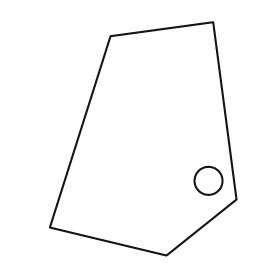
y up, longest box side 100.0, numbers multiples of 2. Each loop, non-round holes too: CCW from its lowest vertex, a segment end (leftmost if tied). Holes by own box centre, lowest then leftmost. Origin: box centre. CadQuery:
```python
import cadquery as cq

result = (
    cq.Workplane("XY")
    .moveTo(10.0, -50.0)
    .lineTo(40.0, -26.0)
    .lineTo(30.0, 50.0)
    .lineTo(-14.0, 44.0)
    .lineTo(-40.0, -38.0)
    .close()
    .moveTo(28.0, -18.0)
    .circle(6.0)
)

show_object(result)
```